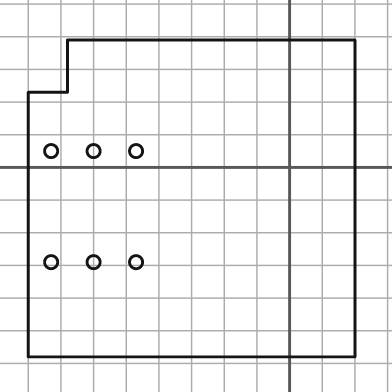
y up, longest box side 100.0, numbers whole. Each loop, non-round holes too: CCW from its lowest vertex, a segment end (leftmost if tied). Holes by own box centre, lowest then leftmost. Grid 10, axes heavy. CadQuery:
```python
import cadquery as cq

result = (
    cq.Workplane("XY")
    .moveTo(-80.0, -58.0)
    .lineTo(20.0, -58.0)
    .lineTo(20.0, 39.0)
    .lineTo(-68.0, 39.0)
    .lineTo(-68.0, 23.0)
    .lineTo(-80.0, 23.0)
    .close()
    .moveTo(-73.0, -29.0)
    .circle(2.0)
    .moveTo(-60.0, -29.0)
    .circle(2.0)
    .moveTo(-47.0, -29.0)
    .circle(2.0)
    .moveTo(-73.0, 5.0)
    .circle(2.0)
    .moveTo(-60.0, 5.0)
    .circle(2.0)
    .moveTo(-47.0, 5.0)
    .circle(2.0)
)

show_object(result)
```